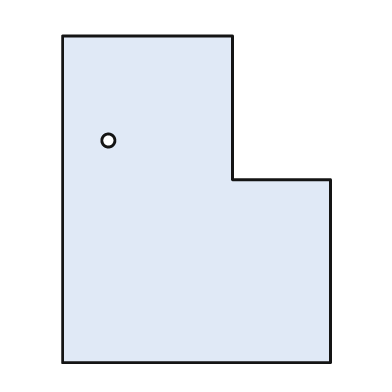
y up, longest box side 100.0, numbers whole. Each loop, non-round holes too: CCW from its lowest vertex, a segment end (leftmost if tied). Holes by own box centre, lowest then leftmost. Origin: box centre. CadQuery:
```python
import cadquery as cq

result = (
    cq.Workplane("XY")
    .moveTo(-41.0, -50.0)
    .lineTo(41.0, -50.0)
    .lineTo(41.0, 6.0)
    .lineTo(11.0, 6.0)
    .lineTo(11.0, 50.0)
    .lineTo(-41.0, 50.0)
    .close()
    .moveTo(-27.0, 18.0)
    .circle(2.0)
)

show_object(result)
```